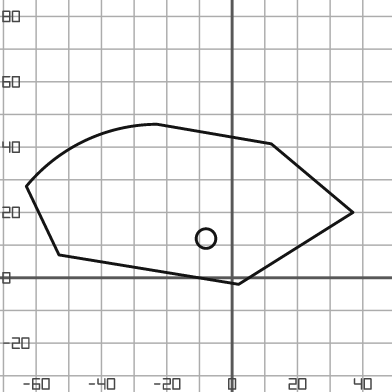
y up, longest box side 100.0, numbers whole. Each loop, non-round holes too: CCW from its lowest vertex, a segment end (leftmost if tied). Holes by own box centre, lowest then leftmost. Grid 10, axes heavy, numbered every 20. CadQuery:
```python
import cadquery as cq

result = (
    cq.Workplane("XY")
    .moveTo(2.0, -2.0)
    .lineTo(37.0, 20.0)
    .lineTo(12.0, 41.0)
    .lineTo(-23.0, 47.0)
    .threePointArc((-45.0, 42.0), (-63.0, 28.0))
    .lineTo(-53.0, 7.0)
    .close()
    .moveTo(-8.0, 12.0)
    .circle(3.0)
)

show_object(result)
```